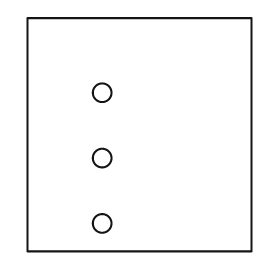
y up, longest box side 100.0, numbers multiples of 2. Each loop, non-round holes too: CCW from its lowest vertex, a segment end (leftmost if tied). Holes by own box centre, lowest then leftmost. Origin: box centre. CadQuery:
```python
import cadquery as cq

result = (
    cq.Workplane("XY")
    .moveTo(-48.0, -50.0)
    .lineTo(48.0, -50.0)
    .lineTo(48.0, 50.0)
    .lineTo(-48.0, 50.0)
    .close()
    .moveTo(-16.0, -38.0)
    .circle(4.0)
    .moveTo(-16.0, -10.0)
    .circle(4.0)
    .moveTo(-16.0, 18.0)
    .circle(4.0)
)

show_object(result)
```